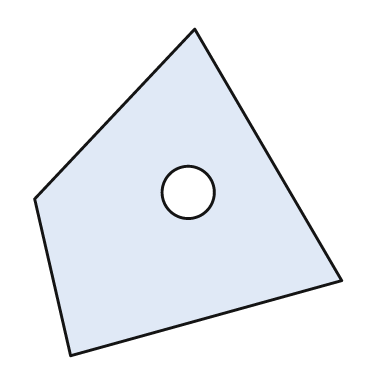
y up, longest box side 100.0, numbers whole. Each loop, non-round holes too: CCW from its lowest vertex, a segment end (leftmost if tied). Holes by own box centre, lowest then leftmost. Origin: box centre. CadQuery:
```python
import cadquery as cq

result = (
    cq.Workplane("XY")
    .moveTo(-36.0, -50.0)
    .lineTo(47.0, -27.0)
    .lineTo(2.0, 50.0)
    .lineTo(-47.0, -2.0)
    .close()
    .moveTo(0.0, 0.0)
    .circle(8.0)
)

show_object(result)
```